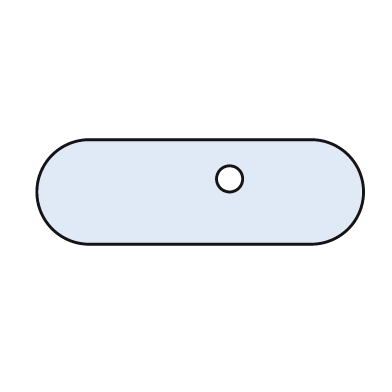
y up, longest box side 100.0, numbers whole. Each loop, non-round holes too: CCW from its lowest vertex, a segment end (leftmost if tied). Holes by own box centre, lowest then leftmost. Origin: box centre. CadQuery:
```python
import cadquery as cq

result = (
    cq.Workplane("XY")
    .moveTo(-34.0, -16.0)
    .lineTo(34.0, -16.0)
    .threePointArc((50.0, 0.0), (34.0, 16.0))
    .lineTo(-34.0, 16.0)
    .threePointArc((-50.0, 0.0), (-34.0, -16.0))
    .close()
    .moveTo(9.0, 4.0)
    .circle(4.0)
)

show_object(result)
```